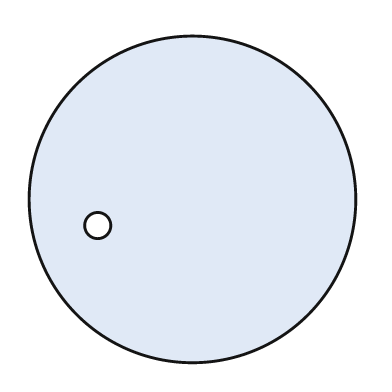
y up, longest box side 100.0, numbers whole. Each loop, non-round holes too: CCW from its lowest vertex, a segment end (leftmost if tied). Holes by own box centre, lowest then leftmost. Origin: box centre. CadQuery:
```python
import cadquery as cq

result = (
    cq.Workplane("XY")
    .moveTo(0.0, 0.0)
    .circle(50.0)
    .moveTo(-29.0, -8.0)
    .circle(4.0)
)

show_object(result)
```